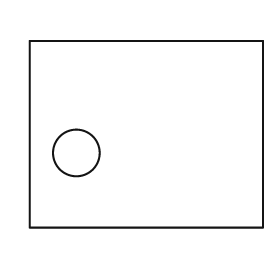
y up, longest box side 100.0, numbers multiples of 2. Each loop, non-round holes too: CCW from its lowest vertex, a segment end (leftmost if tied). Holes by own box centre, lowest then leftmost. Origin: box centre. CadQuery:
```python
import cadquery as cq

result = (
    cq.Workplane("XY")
    .moveTo(-50.0, -40.0)
    .lineTo(50.0, -40.0)
    .lineTo(50.0, 40.0)
    .lineTo(-50.0, 40.0)
    .close()
    .moveTo(-30.0, -8.0)
    .circle(10.0)
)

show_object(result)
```